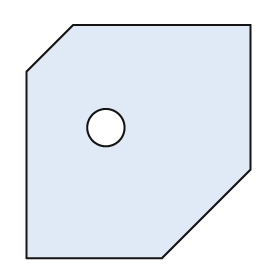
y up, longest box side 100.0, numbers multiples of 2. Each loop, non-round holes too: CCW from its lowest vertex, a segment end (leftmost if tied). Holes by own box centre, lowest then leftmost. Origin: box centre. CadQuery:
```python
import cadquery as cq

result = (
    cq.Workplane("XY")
    .moveTo(-48.0, -50.0)
    .lineTo(10.0, -50.0)
    .lineTo(48.0, -12.0)
    .lineTo(48.0, 50.0)
    .lineTo(-28.0, 50.0)
    .lineTo(-48.0, 30.0)
    .close()
    .moveTo(-14.0, 6.0)
    .circle(8.0)
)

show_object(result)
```